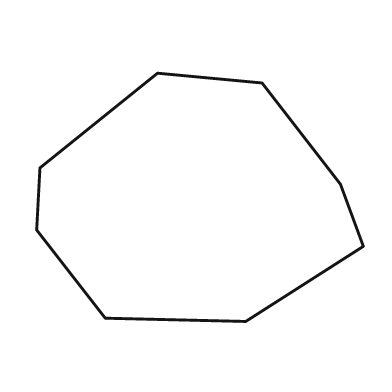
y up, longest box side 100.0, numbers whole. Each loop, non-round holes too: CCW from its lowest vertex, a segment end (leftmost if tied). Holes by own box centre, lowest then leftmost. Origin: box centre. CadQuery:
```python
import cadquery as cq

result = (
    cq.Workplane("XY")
    .moveTo(14.0, -38.0)
    .lineTo(50.0, -15.0)
    .lineTo(43.0, 4.0)
    .lineTo(19.0, 35.0)
    .lineTo(-13.0, 38.0)
    .lineTo(-49.0, 9.0)
    .lineTo(-50.0, -10.0)
    .lineTo(-29.0, -37.0)
    .close()
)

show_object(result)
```